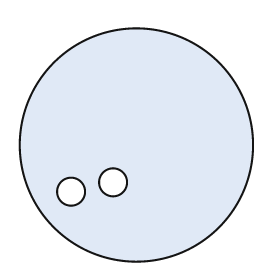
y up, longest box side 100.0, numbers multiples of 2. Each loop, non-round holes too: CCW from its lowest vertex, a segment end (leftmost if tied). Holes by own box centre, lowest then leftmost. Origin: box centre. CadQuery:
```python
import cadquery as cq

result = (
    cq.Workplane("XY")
    .moveTo(0.0, 0.0)
    .circle(50.0)
    .moveTo(-28.0, -20.0)
    .circle(6.0)
    .moveTo(-10.0, -16.0)
    .circle(6.0)
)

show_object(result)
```